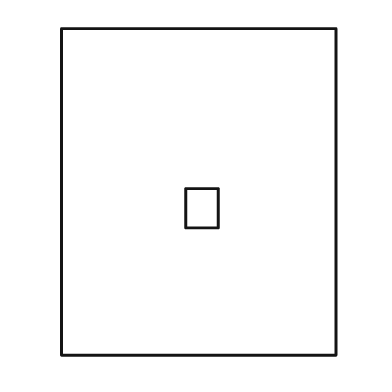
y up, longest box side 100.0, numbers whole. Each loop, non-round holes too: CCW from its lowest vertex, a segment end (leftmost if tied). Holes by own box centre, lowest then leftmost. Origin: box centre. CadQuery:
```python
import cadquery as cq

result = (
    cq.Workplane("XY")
    .moveTo(-42.0, -50.0)
    .lineTo(42.0, -50.0)
    .lineTo(42.0, 50.0)
    .lineTo(-42.0, 50.0)
    .close()
    .moveTo(-4.0, -11.0)
    .lineTo(6.0, -11.0)
    .lineTo(6.0, 1.0)
    .lineTo(-4.0, 1.0)
    .close()
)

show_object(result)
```